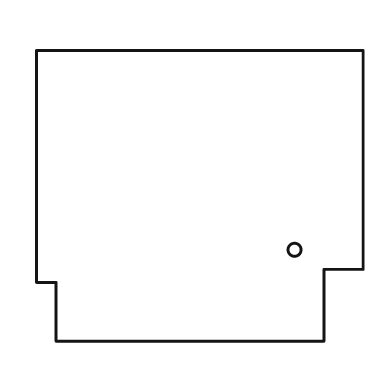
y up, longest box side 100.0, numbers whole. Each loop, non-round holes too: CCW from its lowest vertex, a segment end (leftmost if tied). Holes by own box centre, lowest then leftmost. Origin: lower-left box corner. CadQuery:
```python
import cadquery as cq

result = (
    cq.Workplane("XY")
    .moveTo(6.0, 0.0)
    .lineTo(88.0, 0.0)
    .lineTo(88.0, 22.0)
    .lineTo(100.0, 22.0)
    .lineTo(100.0, 89.0)
    .lineTo(0.0, 89.0)
    .lineTo(0.0, 18.0)
    .lineTo(6.0, 18.0)
    .close()
    .moveTo(79.0, 28.0)
    .circle(2.0)
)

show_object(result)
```